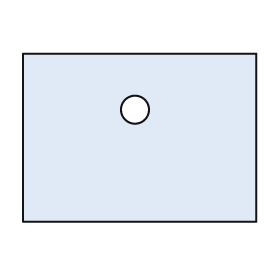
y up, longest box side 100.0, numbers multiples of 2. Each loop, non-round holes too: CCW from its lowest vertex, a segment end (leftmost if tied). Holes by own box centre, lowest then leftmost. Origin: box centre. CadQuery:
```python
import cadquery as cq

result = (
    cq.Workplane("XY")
    .moveTo(-50.0, -36.0)
    .lineTo(50.0, -36.0)
    .lineTo(50.0, 36.0)
    .lineTo(-50.0, 36.0)
    .close()
    .moveTo(-2.0, 12.0)
    .circle(6.0)
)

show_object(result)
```